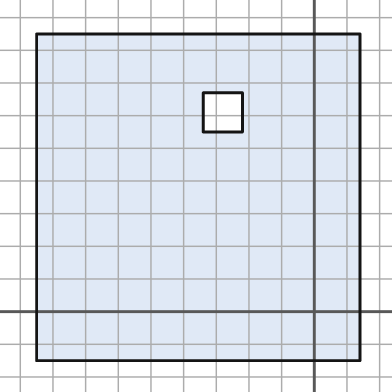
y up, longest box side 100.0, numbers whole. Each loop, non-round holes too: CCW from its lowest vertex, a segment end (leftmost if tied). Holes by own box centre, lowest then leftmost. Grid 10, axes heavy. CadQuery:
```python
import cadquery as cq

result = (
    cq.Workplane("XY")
    .moveTo(-85.0, -15.0)
    .lineTo(14.0, -15.0)
    .lineTo(14.0, 85.0)
    .lineTo(-85.0, 85.0)
    .close()
    .moveTo(-34.0, 55.0)
    .lineTo(-22.0, 55.0)
    .lineTo(-22.0, 67.0)
    .lineTo(-34.0, 67.0)
    .close()
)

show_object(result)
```